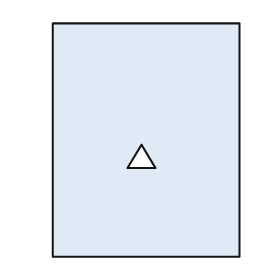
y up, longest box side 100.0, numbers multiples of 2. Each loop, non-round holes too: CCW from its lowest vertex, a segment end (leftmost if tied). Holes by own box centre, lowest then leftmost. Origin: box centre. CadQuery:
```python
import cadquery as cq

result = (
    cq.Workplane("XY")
    .moveTo(-40.0, -50.0)
    .lineTo(40.0, -50.0)
    .lineTo(40.0, 50.0)
    .lineTo(-40.0, 50.0)
    .close()
    .moveTo(-8.0, -12.0)
    .lineTo(4.0, -12.0)
    .lineTo(-2.0, -2.0)
    .close()
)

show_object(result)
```